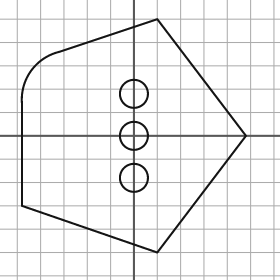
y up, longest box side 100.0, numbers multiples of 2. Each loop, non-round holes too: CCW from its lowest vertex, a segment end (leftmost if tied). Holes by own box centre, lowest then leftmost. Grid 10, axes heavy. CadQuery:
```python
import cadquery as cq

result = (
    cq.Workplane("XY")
    .moveTo(10.0, -50.0)
    .lineTo(48.0, 0.0)
    .lineTo(10.0, 50.0)
    .lineTo(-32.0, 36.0)
    .threePointArc((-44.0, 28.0), (-48.0, 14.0))
    .lineTo(-48.0, -30.0)
    .close()
    .moveTo(0.0, -18.0)
    .circle(6.0)
    .moveTo(0.0, 0.0)
    .circle(6.0)
    .moveTo(0.0, 18.0)
    .circle(6.0)
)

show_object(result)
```